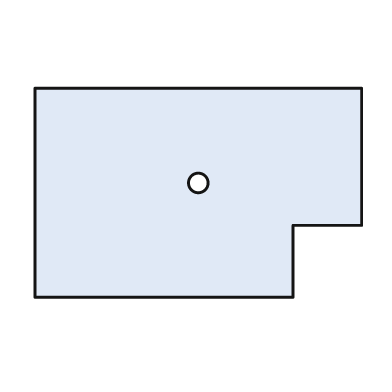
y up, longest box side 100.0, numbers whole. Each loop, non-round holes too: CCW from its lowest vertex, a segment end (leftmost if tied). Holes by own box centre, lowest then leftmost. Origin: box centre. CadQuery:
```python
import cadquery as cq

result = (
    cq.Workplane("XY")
    .moveTo(-50.0, -32.0)
    .lineTo(29.0, -32.0)
    .lineTo(29.0, -10.0)
    .lineTo(50.0, -10.0)
    .lineTo(50.0, 32.0)
    .lineTo(-50.0, 32.0)
    .close()
    .moveTo(0.0, 3.0)
    .circle(3.0)
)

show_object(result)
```